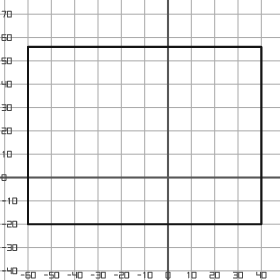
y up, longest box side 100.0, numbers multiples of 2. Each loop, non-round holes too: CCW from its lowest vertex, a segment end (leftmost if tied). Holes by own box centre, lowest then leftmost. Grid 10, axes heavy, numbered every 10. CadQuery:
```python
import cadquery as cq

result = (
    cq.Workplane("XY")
    .moveTo(-60.0, -20.0)
    .lineTo(40.0, -20.0)
    .lineTo(40.0, 56.0)
    .lineTo(-60.0, 56.0)
    .close()
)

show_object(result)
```